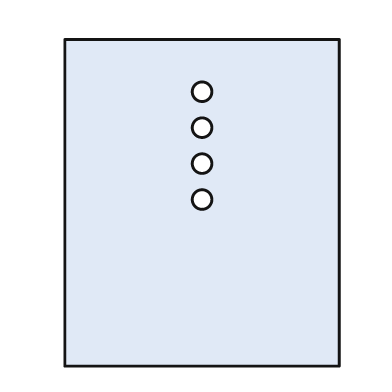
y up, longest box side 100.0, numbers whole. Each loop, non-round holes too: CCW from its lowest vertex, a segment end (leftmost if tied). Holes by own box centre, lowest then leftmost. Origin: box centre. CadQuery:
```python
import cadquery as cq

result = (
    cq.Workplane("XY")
    .moveTo(-42.0, -50.0)
    .lineTo(42.0, -50.0)
    .lineTo(42.0, 50.0)
    .lineTo(-42.0, 50.0)
    .close()
    .moveTo(0.0, 1.0)
    .circle(3.0)
    .moveTo(0.0, 12.0)
    .circle(3.0)
    .moveTo(0.0, 23.0)
    .circle(3.0)
    .moveTo(0.0, 34.0)
    .circle(3.0)
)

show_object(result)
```